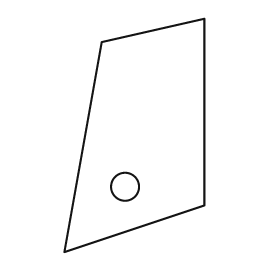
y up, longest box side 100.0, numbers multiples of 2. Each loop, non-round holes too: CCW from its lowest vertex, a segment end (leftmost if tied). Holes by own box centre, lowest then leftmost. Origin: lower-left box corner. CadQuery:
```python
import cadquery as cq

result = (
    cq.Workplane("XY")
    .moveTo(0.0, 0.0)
    .lineTo(60.0, 20.0)
    .lineTo(60.0, 100.0)
    .lineTo(16.0, 90.0)
    .close()
    .moveTo(26.0, 28.0)
    .circle(6.0)
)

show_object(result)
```